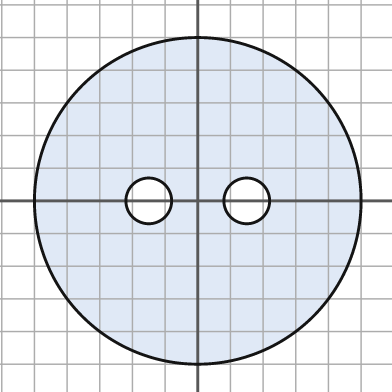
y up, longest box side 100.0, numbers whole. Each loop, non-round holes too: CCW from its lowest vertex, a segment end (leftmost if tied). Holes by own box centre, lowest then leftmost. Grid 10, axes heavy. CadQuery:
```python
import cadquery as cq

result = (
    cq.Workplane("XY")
    .moveTo(0.0, 0.0)
    .circle(50.0)
    .moveTo(-15.0, 0.0)
    .circle(7.0)
    .moveTo(15.0, 0.0)
    .circle(7.0)
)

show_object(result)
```